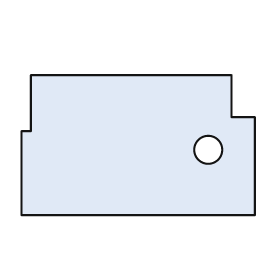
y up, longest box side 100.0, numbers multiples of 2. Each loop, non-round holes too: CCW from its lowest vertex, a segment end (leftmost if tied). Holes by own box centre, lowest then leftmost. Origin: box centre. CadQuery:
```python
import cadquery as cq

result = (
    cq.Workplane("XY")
    .moveTo(-50.0, -30.0)
    .lineTo(50.0, -30.0)
    .lineTo(50.0, 12.0)
    .lineTo(40.0, 12.0)
    .lineTo(40.0, 30.0)
    .lineTo(-46.0, 30.0)
    .lineTo(-46.0, 6.0)
    .lineTo(-50.0, 6.0)
    .close()
    .moveTo(30.0, -2.0)
    .circle(6.0)
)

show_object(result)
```